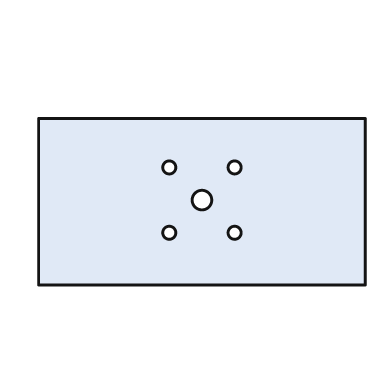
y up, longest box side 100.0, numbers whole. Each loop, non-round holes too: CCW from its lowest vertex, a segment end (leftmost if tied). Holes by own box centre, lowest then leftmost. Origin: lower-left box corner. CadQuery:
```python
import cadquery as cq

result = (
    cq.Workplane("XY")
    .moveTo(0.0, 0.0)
    .lineTo(100.0, 0.0)
    .lineTo(100.0, 51.0)
    .lineTo(0.0, 51.0)
    .close()
    .moveTo(40.0, 16.0)
    .circle(2.0)
    .moveTo(60.0, 16.0)
    .circle(2.0)
    .moveTo(50.0, 26.0)
    .circle(3.0)
    .moveTo(40.0, 36.0)
    .circle(2.0)
    .moveTo(60.0, 36.0)
    .circle(2.0)
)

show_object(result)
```